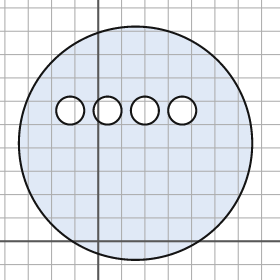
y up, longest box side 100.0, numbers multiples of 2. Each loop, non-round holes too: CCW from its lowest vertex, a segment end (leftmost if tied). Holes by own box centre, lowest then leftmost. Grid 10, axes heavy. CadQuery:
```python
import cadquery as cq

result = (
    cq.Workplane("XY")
    .moveTo(16.0, 42.0)
    .circle(50.0)
    .moveTo(-12.0, 56.0)
    .circle(6.0)
    .moveTo(4.0, 56.0)
    .circle(6.0)
    .moveTo(20.0, 56.0)
    .circle(6.0)
    .moveTo(36.0, 56.0)
    .circle(6.0)
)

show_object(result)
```